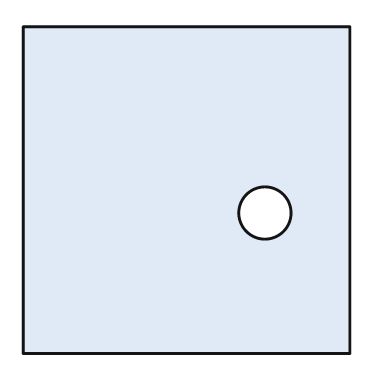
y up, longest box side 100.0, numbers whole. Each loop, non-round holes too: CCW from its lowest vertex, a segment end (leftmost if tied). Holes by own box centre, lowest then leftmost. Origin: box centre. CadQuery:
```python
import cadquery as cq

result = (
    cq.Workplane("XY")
    .moveTo(-50.0, -50.0)
    .lineTo(50.0, -50.0)
    .lineTo(50.0, 50.0)
    .lineTo(-50.0, 50.0)
    .close()
    .moveTo(24.0, -7.0)
    .circle(8.0)
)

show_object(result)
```